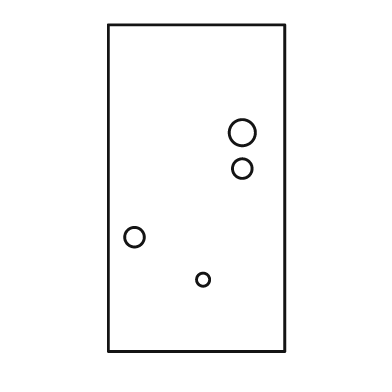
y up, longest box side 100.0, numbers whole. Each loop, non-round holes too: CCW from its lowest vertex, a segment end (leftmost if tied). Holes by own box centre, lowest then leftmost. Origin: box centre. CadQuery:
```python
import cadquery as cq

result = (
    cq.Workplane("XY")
    .moveTo(-27.0, -50.0)
    .lineTo(27.0, -50.0)
    .lineTo(27.0, 50.0)
    .lineTo(-27.0, 50.0)
    .close()
    .moveTo(2.0, -28.0)
    .circle(2.0)
    .moveTo(-19.0, -15.0)
    .circle(3.0)
    .moveTo(14.0, 6.0)
    .circle(3.0)
    .moveTo(14.0, 17.0)
    .circle(4.0)
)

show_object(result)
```